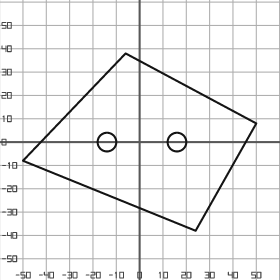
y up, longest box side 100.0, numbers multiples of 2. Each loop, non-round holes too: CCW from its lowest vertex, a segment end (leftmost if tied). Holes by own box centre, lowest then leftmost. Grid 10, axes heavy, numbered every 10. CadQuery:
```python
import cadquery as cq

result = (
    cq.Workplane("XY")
    .moveTo(24.0, -38.0)
    .lineTo(50.0, 8.0)
    .lineTo(-6.0, 38.0)
    .lineTo(-50.0, -8.0)
    .close()
    .moveTo(-14.0, 0.0)
    .circle(4.0)
    .moveTo(16.0, 0.0)
    .circle(4.0)
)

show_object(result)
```